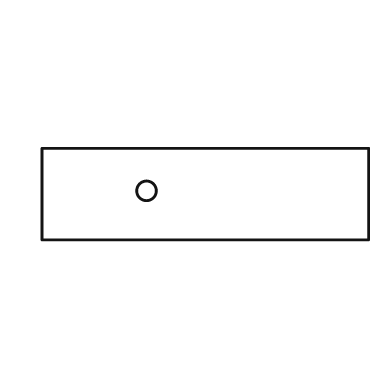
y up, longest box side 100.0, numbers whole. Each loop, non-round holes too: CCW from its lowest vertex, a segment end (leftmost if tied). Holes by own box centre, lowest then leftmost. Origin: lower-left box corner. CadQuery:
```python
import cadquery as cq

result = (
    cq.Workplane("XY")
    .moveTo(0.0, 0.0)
    .lineTo(100.0, 0.0)
    .lineTo(100.0, 28.0)
    .lineTo(0.0, 28.0)
    .close()
    .moveTo(32.0, 15.0)
    .circle(3.0)
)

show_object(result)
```